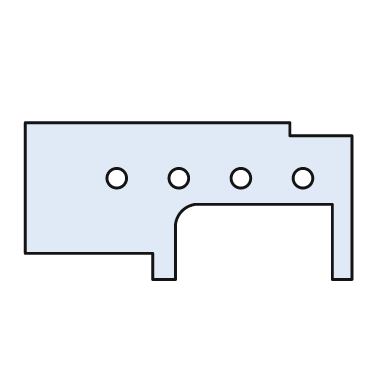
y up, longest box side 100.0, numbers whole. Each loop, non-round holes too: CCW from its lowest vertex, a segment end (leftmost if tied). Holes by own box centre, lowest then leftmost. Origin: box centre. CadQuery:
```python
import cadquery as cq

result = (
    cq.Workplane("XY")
    .moveTo(-11.0, -24.0)
    .lineTo(-4.0, -24.0)
    .lineTo(-4.0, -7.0)
    .threePointArc((-2.0, -3.0), (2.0, -1.0))
    .lineTo(44.0, -1.0)
    .lineTo(44.0, -24.0)
    .lineTo(50.0, -24.0)
    .lineTo(50.0, 20.0)
    .lineTo(31.0, 20.0)
    .lineTo(31.0, 24.0)
    .lineTo(-50.0, 24.0)
    .lineTo(-50.0, -16.0)
    .lineTo(-11.0, -16.0)
    .close()
    .moveTo(-22.0, 7.0)
    .circle(3.0)
    .moveTo(-3.0, 7.0)
    .circle(3.0)
    .moveTo(16.0, 7.0)
    .circle(3.0)
    .moveTo(35.0, 7.0)
    .circle(3.0)
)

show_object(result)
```